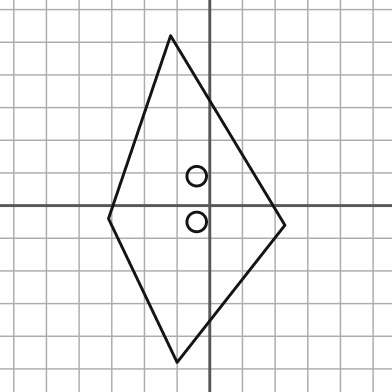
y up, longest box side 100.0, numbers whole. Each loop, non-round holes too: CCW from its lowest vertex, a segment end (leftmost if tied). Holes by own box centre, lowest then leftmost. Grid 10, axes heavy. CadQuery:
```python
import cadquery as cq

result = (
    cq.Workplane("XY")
    .moveTo(-10.0, -48.0)
    .lineTo(23.0, -6.0)
    .lineTo(-12.0, 52.0)
    .lineTo(-31.0, -4.0)
    .close()
    .moveTo(-4.0, -5.0)
    .circle(3.0)
    .moveTo(-4.0, 9.0)
    .circle(3.0)
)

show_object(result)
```